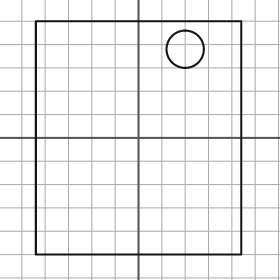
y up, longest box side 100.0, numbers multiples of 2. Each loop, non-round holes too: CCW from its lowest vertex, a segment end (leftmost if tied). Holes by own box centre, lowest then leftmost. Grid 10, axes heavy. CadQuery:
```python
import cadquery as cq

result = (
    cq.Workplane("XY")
    .moveTo(-44.0, -50.0)
    .lineTo(44.0, -50.0)
    .lineTo(44.0, 50.0)
    .lineTo(-44.0, 50.0)
    .close()
    .moveTo(20.0, 38.0)
    .circle(8.0)
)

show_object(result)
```